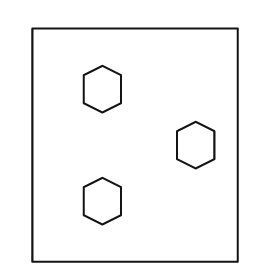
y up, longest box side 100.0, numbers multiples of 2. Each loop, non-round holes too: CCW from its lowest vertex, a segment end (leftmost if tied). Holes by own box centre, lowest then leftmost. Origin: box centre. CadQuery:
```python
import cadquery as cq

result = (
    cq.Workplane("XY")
    .moveTo(-44.0, -50.0)
    .lineTo(44.0, -50.0)
    .lineTo(44.0, 50.0)
    .lineTo(-44.0, 50.0)
    .close()
    .moveTo(-14.0, -34.0)
    .lineTo(-6.0, -30.0)
    .lineTo(-6.0, -18.0)
    .lineTo(-14.0, -14.0)
    .lineTo(-22.0, -18.0)
    .lineTo(-22.0, -30.0)
    .close()
    .moveTo(26.0, -10.0)
    .lineTo(34.0, -6.0)
    .lineTo(34.0, 6.0)
    .lineTo(26.0, 10.0)
    .lineTo(18.0, 6.0)
    .lineTo(18.0, -6.0)
    .close()
    .moveTo(-14.0, 14.0)
    .lineTo(-6.0, 18.0)
    .lineTo(-6.0, 30.0)
    .lineTo(-14.0, 34.0)
    .lineTo(-22.0, 30.0)
    .lineTo(-22.0, 18.0)
    .close()
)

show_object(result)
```